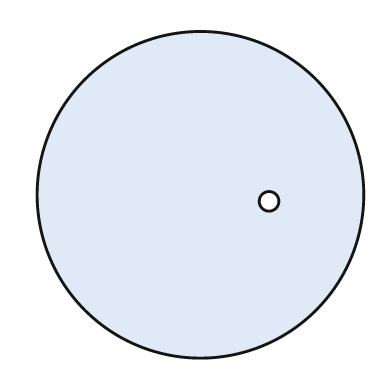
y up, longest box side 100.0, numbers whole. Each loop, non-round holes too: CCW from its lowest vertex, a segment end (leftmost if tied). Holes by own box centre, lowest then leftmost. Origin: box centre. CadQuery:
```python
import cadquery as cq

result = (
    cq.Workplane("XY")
    .moveTo(0.0, 0.0)
    .circle(50.0)
    .moveTo(21.0, -2.0)
    .circle(3.0)
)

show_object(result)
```